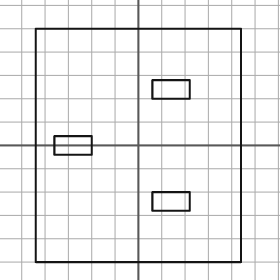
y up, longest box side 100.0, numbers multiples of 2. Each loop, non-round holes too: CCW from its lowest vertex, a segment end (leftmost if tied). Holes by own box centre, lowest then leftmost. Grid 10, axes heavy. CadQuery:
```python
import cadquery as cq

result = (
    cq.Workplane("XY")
    .moveTo(-44.0, -50.0)
    .lineTo(44.0, -50.0)
    .lineTo(44.0, 50.0)
    .lineTo(-44.0, 50.0)
    .close()
    .moveTo(6.0, -28.0)
    .lineTo(22.0, -28.0)
    .lineTo(22.0, -20.0)
    .lineTo(6.0, -20.0)
    .close()
    .moveTo(-36.0, -4.0)
    .lineTo(-20.0, -4.0)
    .lineTo(-20.0, 4.0)
    .lineTo(-36.0, 4.0)
    .close()
    .moveTo(6.0, 20.0)
    .lineTo(22.0, 20.0)
    .lineTo(22.0, 28.0)
    .lineTo(6.0, 28.0)
    .close()
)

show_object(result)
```